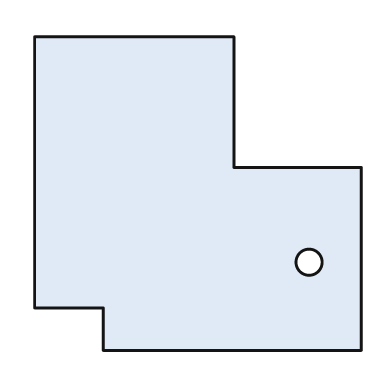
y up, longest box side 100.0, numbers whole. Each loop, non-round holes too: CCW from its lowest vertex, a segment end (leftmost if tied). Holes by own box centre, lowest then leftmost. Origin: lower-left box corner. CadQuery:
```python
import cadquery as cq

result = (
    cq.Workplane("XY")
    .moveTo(21.0, 0.0)
    .lineTo(100.0, 0.0)
    .lineTo(100.0, 56.0)
    .lineTo(61.0, 56.0)
    .lineTo(61.0, 96.0)
    .lineTo(0.0, 96.0)
    .lineTo(0.0, 13.0)
    .lineTo(21.0, 13.0)
    .close()
    .moveTo(84.0, 27.0)
    .circle(4.0)
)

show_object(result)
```